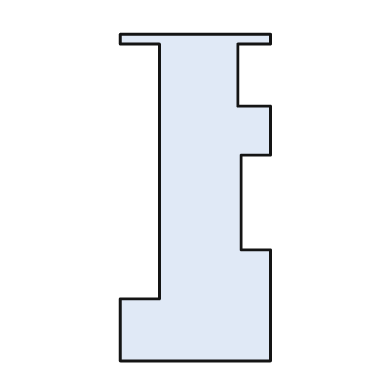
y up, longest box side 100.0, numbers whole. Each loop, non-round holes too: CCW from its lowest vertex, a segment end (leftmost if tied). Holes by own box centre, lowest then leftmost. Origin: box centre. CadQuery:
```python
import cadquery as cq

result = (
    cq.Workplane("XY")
    .moveTo(-23.0, -50.0)
    .lineTo(23.0, -50.0)
    .lineTo(23.0, -16.0)
    .lineTo(14.0, -16.0)
    .lineTo(14.0, 13.0)
    .lineTo(23.0, 13.0)
    .lineTo(23.0, 28.0)
    .lineTo(13.0, 28.0)
    .lineTo(13.0, 47.0)
    .lineTo(23.0, 47.0)
    .lineTo(23.0, 50.0)
    .lineTo(-23.0, 50.0)
    .lineTo(-23.0, 47.0)
    .lineTo(-11.0, 47.0)
    .lineTo(-11.0, -31.0)
    .lineTo(-23.0, -31.0)
    .close()
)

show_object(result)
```